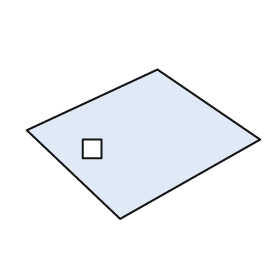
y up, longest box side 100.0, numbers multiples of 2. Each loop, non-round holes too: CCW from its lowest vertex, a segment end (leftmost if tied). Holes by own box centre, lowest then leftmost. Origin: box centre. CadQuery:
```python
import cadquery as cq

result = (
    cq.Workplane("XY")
    .moveTo(-10.0, -32.0)
    .lineTo(50.0, 2.0)
    .lineTo(6.0, 32.0)
    .lineTo(-50.0, 6.0)
    .close()
    .moveTo(-26.0, -6.0)
    .lineTo(-18.0, -6.0)
    .lineTo(-18.0, 2.0)
    .lineTo(-26.0, 2.0)
    .close()
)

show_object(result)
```